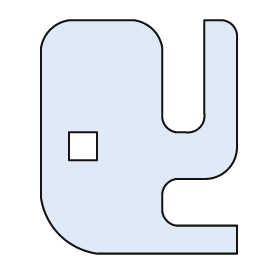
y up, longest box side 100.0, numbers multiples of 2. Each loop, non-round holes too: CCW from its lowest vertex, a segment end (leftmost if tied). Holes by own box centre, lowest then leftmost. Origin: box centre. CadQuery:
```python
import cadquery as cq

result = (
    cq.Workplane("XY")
    .moveTo(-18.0, -50.0)
    .lineTo(42.0, -50.0)
    .lineTo(42.0, -38.0)
    .lineTo(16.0, -38.0)
    .threePointArc((12.0, -36.0), (10.0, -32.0))
    .lineTo(10.0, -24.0)
    .threePointArc((12.0, -20.0), (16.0, -18.0))
    .lineTo(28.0, -18.0)
    .threePointArc((38.0, -14.0), (42.0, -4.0))
    .lineTo(42.0, 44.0)
    .threePointArc((40.0, 48.0), (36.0, 50.0))
    .lineTo(28.0, 50.0)
    .lineTo(28.0, 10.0)
    .threePointArc((26.0, 4.0), (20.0, 2.0))
    .lineTo(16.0, 2.0)
    .threePointArc((12.0, 4.0), (10.0, 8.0))
    .lineTo(10.0, 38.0)
    .threePointArc((6.0, 46.0), (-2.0, 50.0))
    .lineTo(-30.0, 50.0)
    .threePointArc((-38.0, 46.0), (-42.0, 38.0))
    .lineTo(-42.0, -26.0)
    .threePointArc((-34.0, -42.0), (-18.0, -50.0))
    .close()
    .moveTo(-30.0, -10.0)
    .lineTo(-18.0, -10.0)
    .lineTo(-18.0, 2.0)
    .lineTo(-30.0, 2.0)
    .close()
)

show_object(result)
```